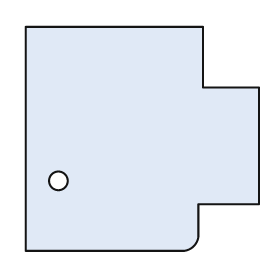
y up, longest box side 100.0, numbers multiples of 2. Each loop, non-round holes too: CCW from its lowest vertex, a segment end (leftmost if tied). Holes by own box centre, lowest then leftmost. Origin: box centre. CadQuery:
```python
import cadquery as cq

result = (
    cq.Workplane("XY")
    .moveTo(-50.0, -48.0)
    .lineTo(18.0, -48.0)
    .threePointArc((22.0, -46.0), (24.0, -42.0))
    .lineTo(24.0, -28.0)
    .lineTo(50.0, -28.0)
    .lineTo(50.0, 22.0)
    .lineTo(26.0, 22.0)
    .lineTo(26.0, 48.0)
    .lineTo(-50.0, 48.0)
    .close()
    .moveTo(-36.0, -18.0)
    .circle(4.0)
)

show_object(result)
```